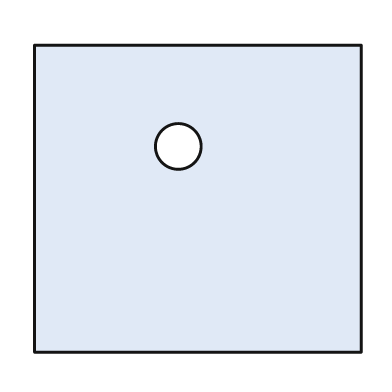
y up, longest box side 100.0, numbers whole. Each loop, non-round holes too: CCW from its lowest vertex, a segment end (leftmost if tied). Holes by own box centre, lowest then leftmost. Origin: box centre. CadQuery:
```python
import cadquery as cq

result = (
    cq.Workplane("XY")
    .moveTo(-50.0, -47.0)
    .lineTo(50.0, -47.0)
    .lineTo(50.0, 47.0)
    .lineTo(-50.0, 47.0)
    .close()
    .moveTo(-6.0, 16.0)
    .circle(7.0)
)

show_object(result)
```